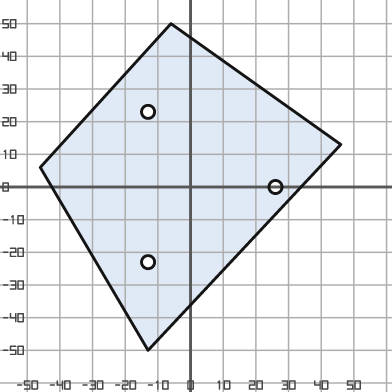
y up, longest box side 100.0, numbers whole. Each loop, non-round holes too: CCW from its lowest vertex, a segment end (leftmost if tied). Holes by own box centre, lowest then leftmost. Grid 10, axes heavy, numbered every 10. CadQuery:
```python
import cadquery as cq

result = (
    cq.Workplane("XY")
    .moveTo(-13.0, -50.0)
    .lineTo(46.0, 13.0)
    .lineTo(-6.0, 50.0)
    .lineTo(-46.0, 6.0)
    .close()
    .moveTo(-13.0, -23.0)
    .circle(2.0)
    .moveTo(26.0, 0.0)
    .circle(2.0)
    .moveTo(-13.0, 23.0)
    .circle(2.0)
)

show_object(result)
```